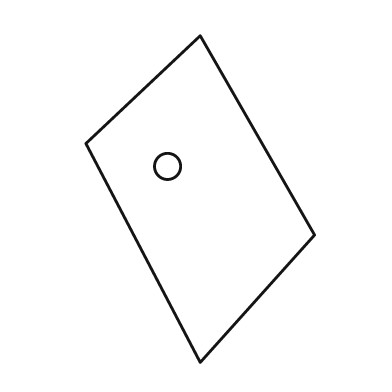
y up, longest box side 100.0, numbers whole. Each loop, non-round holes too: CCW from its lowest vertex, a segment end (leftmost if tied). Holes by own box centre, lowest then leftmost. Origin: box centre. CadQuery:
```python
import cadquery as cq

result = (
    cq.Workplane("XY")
    .moveTo(0.0, -50.0)
    .lineTo(35.0, -11.0)
    .lineTo(0.0, 50.0)
    .lineTo(-35.0, 17.0)
    .close()
    .moveTo(-10.0, 10.0)
    .circle(4.0)
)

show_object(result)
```